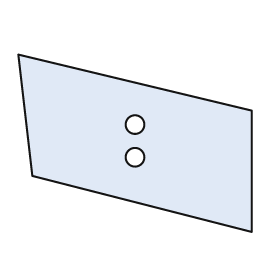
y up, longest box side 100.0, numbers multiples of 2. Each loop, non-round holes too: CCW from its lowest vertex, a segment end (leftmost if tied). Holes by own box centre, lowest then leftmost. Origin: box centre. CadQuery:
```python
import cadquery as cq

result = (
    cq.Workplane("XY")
    .moveTo(50.0, -38.0)
    .lineTo(50.0, 14.0)
    .lineTo(-50.0, 38.0)
    .lineTo(-44.0, -14.0)
    .close()
    .moveTo(0.0, -6.0)
    .circle(4.0)
    .moveTo(0.0, 8.0)
    .circle(4.0)
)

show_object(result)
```